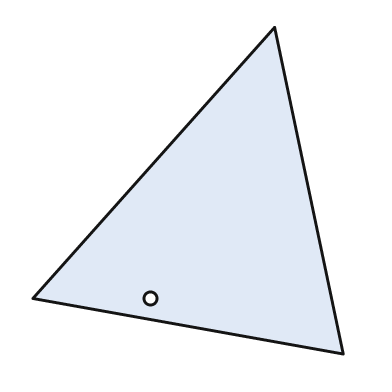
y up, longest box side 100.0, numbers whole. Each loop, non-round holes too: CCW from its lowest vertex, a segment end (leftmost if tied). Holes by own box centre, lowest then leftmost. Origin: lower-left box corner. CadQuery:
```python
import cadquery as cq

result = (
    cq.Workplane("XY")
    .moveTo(95.0, 0.0)
    .lineTo(74.0, 100.0)
    .lineTo(0.0, 17.0)
    .close()
    .moveTo(36.0, 17.0)
    .circle(2.0)
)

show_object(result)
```